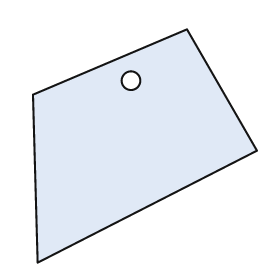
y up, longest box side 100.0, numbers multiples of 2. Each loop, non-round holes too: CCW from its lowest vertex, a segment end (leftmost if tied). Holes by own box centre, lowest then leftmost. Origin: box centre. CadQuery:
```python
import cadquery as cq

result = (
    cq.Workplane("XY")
    .moveTo(-46.0, -50.0)
    .lineTo(48.0, -2.0)
    .lineTo(18.0, 50.0)
    .lineTo(-48.0, 22.0)
    .close()
    .moveTo(-6.0, 28.0)
    .circle(4.0)
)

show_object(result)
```